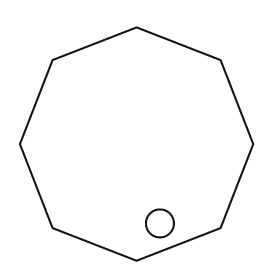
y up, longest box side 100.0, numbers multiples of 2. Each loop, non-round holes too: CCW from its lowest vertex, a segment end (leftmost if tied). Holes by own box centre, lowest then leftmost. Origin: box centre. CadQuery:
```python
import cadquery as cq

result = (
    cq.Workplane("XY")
    .moveTo(0.0, -50.0)
    .lineTo(36.0, -36.0)
    .lineTo(50.0, 0.0)
    .lineTo(36.0, 36.0)
    .lineTo(0.0, 50.0)
    .lineTo(-36.0, 36.0)
    .lineTo(-50.0, 0.0)
    .lineTo(-36.0, -36.0)
    .close()
    .moveTo(10.0, -34.0)
    .circle(6.0)
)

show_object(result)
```